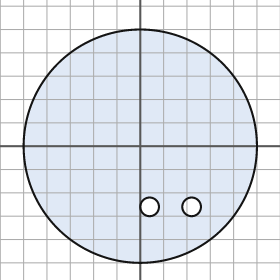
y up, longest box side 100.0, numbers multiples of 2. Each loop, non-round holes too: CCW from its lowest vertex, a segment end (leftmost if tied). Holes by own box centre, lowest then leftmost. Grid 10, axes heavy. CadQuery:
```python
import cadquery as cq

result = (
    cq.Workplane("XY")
    .moveTo(0.0, 0.0)
    .circle(50.0)
    .moveTo(4.0, -26.0)
    .circle(4.0)
    .moveTo(22.0, -26.0)
    .circle(4.0)
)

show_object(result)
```